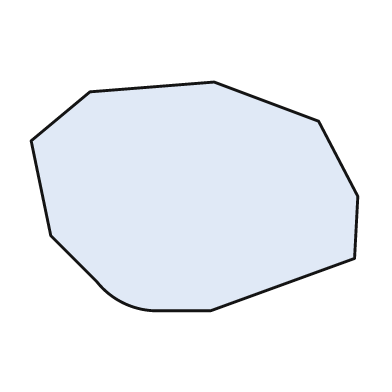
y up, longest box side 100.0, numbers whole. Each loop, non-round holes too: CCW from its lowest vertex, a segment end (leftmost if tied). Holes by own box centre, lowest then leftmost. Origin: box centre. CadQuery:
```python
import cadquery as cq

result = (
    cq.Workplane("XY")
    .moveTo(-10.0, -35.0)
    .lineTo(5.0, -35.0)
    .lineTo(49.0, -19.0)
    .lineTo(50.0, 0.0)
    .lineTo(38.0, 23.0)
    .lineTo(6.0, 35.0)
    .lineTo(-32.0, 32.0)
    .lineTo(-50.0, 17.0)
    .lineTo(-44.0, -12.0)
    .lineTo(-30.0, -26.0)
    .threePointArc((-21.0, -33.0), (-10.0, -35.0))
    .close()
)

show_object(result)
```